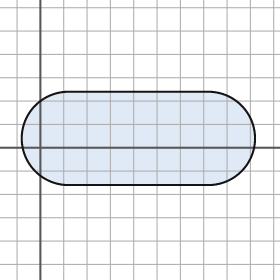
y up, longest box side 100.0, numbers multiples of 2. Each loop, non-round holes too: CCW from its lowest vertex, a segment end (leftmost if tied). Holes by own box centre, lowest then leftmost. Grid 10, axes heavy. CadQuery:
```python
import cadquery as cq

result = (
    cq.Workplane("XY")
    .moveTo(12.0, -16.0)
    .lineTo(72.0, -16.0)
    .threePointArc((92.0, 4.0), (72.0, 24.0))
    .lineTo(12.0, 24.0)
    .threePointArc((-8.0, 4.0), (12.0, -16.0))
    .close()
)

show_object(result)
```